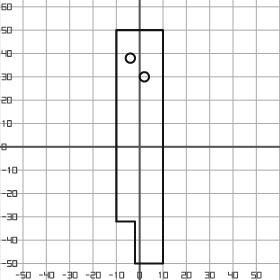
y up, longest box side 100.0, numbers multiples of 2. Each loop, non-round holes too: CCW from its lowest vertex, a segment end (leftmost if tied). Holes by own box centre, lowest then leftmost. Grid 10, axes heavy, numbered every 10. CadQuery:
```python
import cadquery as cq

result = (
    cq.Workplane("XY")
    .moveTo(-2.0, -50.0)
    .lineTo(10.0, -50.0)
    .lineTo(10.0, 50.0)
    .lineTo(-10.0, 50.0)
    .lineTo(-10.0, -32.0)
    .lineTo(-2.0, -32.0)
    .close()
    .moveTo(2.0, 30.0)
    .circle(2.0)
    .moveTo(-4.0, 38.0)
    .circle(2.0)
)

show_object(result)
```